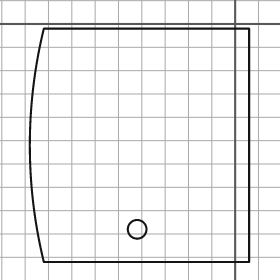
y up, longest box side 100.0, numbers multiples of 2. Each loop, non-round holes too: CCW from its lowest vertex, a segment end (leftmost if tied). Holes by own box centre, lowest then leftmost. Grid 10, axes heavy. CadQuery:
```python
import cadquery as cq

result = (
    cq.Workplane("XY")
    .moveTo(-82.0, -102.0)
    .lineTo(6.0, -102.0)
    .lineTo(6.0, -2.0)
    .lineTo(-82.0, -2.0)
    .threePointArc((-88.0, -52.0), (-82.0, -102.0))
    .close()
    .moveTo(-42.0, -88.0)
    .circle(4.0)
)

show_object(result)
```